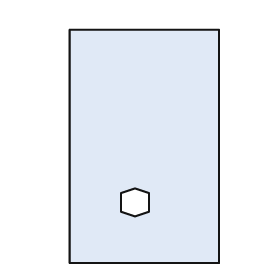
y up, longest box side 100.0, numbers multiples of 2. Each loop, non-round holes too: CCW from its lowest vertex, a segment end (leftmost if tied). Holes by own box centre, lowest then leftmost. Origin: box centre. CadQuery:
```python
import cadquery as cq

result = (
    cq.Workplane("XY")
    .moveTo(-32.0, -50.0)
    .lineTo(32.0, -50.0)
    .lineTo(32.0, 50.0)
    .lineTo(-32.0, 50.0)
    .close()
    .moveTo(-4.0, -30.0)
    .lineTo(2.0, -28.0)
    .lineTo(2.0, -20.0)
    .lineTo(-4.0, -18.0)
    .lineTo(-10.0, -20.0)
    .lineTo(-10.0, -28.0)
    .close()
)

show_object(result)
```